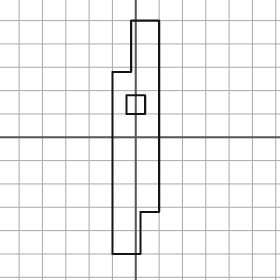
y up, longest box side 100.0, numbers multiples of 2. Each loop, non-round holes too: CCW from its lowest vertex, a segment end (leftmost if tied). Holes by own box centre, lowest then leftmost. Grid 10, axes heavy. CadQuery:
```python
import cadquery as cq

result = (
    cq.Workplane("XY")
    .moveTo(-10.0, -50.0)
    .lineTo(2.0, -50.0)
    .lineTo(2.0, -32.0)
    .lineTo(10.0, -32.0)
    .lineTo(10.0, 50.0)
    .lineTo(-2.0, 50.0)
    .lineTo(-2.0, 28.0)
    .lineTo(-10.0, 28.0)
    .close()
    .moveTo(-4.0, 10.0)
    .lineTo(4.0, 10.0)
    .lineTo(4.0, 18.0)
    .lineTo(-4.0, 18.0)
    .close()
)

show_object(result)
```